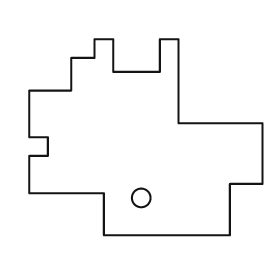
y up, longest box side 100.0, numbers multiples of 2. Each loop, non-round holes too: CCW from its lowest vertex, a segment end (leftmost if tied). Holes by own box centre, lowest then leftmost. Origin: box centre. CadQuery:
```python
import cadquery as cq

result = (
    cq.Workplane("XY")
    .moveTo(-18.0, -42.0)
    .lineTo(36.0, -42.0)
    .lineTo(36.0, -20.0)
    .lineTo(50.0, -20.0)
    .lineTo(50.0, 6.0)
    .lineTo(14.0, 6.0)
    .lineTo(14.0, 42.0)
    .lineTo(6.0, 42.0)
    .lineTo(6.0, 28.0)
    .lineTo(-14.0, 28.0)
    .lineTo(-14.0, 42.0)
    .lineTo(-22.0, 42.0)
    .lineTo(-22.0, 34.0)
    .lineTo(-32.0, 34.0)
    .lineTo(-32.0, 20.0)
    .lineTo(-50.0, 20.0)
    .lineTo(-50.0, 0.0)
    .lineTo(-42.0, 0.0)
    .lineTo(-42.0, -8.0)
    .lineTo(-50.0, -8.0)
    .lineTo(-50.0, -24.0)
    .lineTo(-18.0, -24.0)
    .close()
    .moveTo(-2.0, -26.0)
    .circle(4.0)
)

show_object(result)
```